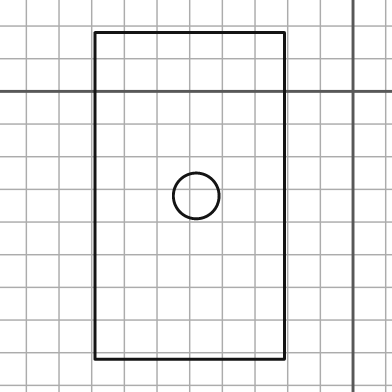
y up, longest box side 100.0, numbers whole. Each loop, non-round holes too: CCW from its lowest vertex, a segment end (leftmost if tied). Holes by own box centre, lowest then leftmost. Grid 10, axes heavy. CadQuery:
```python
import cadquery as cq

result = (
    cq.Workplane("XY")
    .moveTo(-79.0, -82.0)
    .lineTo(-21.0, -82.0)
    .lineTo(-21.0, 18.0)
    .lineTo(-79.0, 18.0)
    .close()
    .moveTo(-48.0, -32.0)
    .circle(7.0)
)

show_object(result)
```